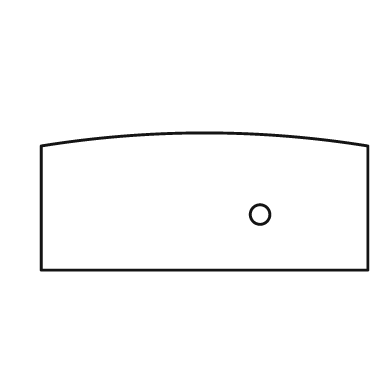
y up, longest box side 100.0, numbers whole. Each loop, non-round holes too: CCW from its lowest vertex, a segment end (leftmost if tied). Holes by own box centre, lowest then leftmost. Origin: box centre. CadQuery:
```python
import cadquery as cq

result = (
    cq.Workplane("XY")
    .moveTo(-50.0, -21.0)
    .lineTo(50.0, -21.0)
    .lineTo(50.0, 17.0)
    .threePointArc((0.0, 21.0), (-50.0, 17.0))
    .close()
    .moveTo(17.0, -4.0)
    .circle(3.0)
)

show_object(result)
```